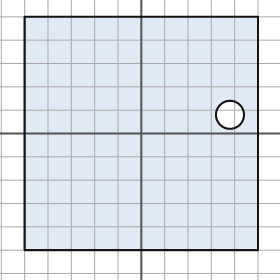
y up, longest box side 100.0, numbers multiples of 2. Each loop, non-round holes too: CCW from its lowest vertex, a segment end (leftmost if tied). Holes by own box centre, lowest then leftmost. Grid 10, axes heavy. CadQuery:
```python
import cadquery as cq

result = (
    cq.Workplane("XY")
    .moveTo(-50.0, -50.0)
    .lineTo(50.0, -50.0)
    .lineTo(50.0, 50.0)
    .lineTo(-50.0, 50.0)
    .close()
    .moveTo(38.0, 8.0)
    .circle(6.0)
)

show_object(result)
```